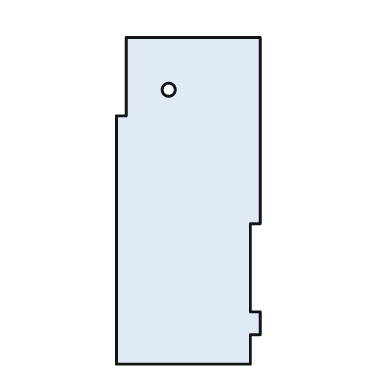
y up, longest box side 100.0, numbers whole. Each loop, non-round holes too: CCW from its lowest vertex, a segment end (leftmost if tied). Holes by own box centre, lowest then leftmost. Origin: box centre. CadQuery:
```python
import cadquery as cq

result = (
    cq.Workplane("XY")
    .moveTo(-22.0, -50.0)
    .lineTo(19.0, -50.0)
    .lineTo(19.0, -41.0)
    .lineTo(22.0, -41.0)
    .lineTo(22.0, -34.0)
    .lineTo(19.0, -34.0)
    .lineTo(19.0, -7.0)
    .lineTo(22.0, -7.0)
    .lineTo(22.0, 50.0)
    .lineTo(-19.0, 50.0)
    .lineTo(-19.0, 26.0)
    .lineTo(-22.0, 26.0)
    .close()
    .moveTo(-6.0, 34.0)
    .circle(2.0)
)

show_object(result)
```